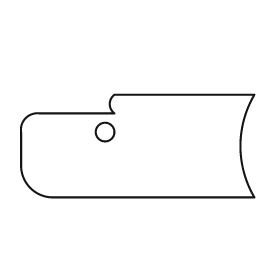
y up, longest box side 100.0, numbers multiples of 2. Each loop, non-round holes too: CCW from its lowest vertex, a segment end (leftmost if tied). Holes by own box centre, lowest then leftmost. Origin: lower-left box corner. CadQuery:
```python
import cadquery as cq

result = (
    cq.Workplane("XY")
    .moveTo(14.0, 0.0)
    .lineTo(100.0, 0.0)
    .threePointArc((94.0, 22.0), (100.0, 44.0))
    .lineTo(40.0, 44.0)
    .threePointArc((38.0, 40.0), (40.0, 36.0))
    .lineTo(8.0, 36.0)
    .threePointArc((2.0, 34.0), (0.0, 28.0))
    .lineTo(0.0, 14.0)
    .threePointArc((4.0, 4.0), (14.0, 0.0))
    .close()
    .moveTo(36.0, 28.0)
    .circle(4.0)
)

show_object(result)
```